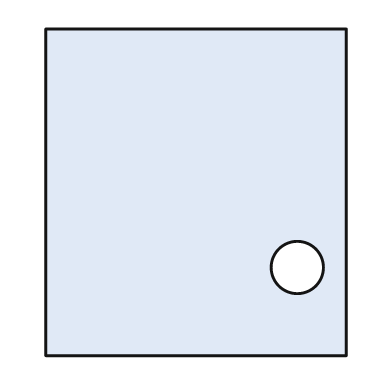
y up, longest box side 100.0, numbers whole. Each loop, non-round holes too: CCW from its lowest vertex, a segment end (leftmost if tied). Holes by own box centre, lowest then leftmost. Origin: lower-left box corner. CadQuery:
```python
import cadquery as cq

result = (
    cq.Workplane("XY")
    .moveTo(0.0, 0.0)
    .lineTo(92.0, 0.0)
    .lineTo(92.0, 100.0)
    .lineTo(0.0, 100.0)
    .close()
    .moveTo(77.0, 27.0)
    .circle(8.0)
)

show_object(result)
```